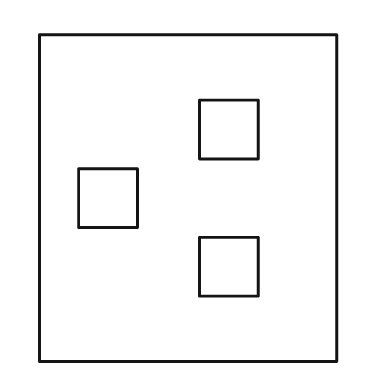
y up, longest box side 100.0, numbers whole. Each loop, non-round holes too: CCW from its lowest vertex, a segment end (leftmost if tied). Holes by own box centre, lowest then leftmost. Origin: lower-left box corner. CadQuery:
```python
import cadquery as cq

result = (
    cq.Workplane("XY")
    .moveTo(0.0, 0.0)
    .lineTo(91.0, 0.0)
    .lineTo(91.0, 100.0)
    .lineTo(0.0, 100.0)
    .close()
    .moveTo(49.0, 20.0)
    .lineTo(67.0, 20.0)
    .lineTo(67.0, 38.0)
    .lineTo(49.0, 38.0)
    .close()
    .moveTo(12.0, 41.0)
    .lineTo(30.0, 41.0)
    .lineTo(30.0, 59.0)
    .lineTo(12.0, 59.0)
    .close()
    .moveTo(49.0, 62.0)
    .lineTo(67.0, 62.0)
    .lineTo(67.0, 80.0)
    .lineTo(49.0, 80.0)
    .close()
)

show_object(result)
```